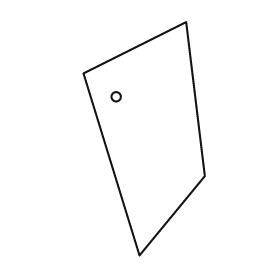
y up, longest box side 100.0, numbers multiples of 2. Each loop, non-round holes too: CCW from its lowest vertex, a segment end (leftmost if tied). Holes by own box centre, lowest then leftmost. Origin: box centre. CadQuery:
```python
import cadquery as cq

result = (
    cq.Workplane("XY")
    .moveTo(-2.0, -50.0)
    .lineTo(26.0, -16.0)
    .lineTo(18.0, 50.0)
    .lineTo(-26.0, 28.0)
    .close()
    .moveTo(-12.0, 18.0)
    .circle(2.0)
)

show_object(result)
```